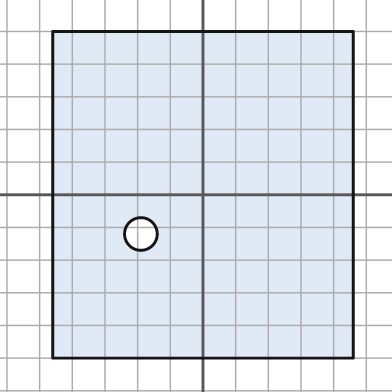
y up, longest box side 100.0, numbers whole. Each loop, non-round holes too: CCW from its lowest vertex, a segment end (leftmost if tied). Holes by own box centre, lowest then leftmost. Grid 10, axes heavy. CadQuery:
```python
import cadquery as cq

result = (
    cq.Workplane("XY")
    .moveTo(-46.0, -50.0)
    .lineTo(46.0, -50.0)
    .lineTo(46.0, 50.0)
    .lineTo(-46.0, 50.0)
    .close()
    .moveTo(-19.0, -12.0)
    .circle(5.0)
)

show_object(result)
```